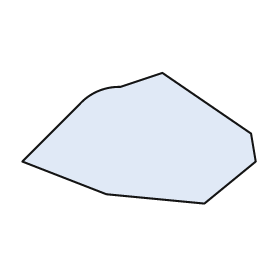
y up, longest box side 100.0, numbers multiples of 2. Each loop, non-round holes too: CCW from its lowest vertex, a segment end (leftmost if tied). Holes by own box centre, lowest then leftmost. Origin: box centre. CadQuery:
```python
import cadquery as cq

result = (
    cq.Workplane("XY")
    .moveTo(28.0, -28.0)
    .lineTo(50.0, -10.0)
    .lineTo(48.0, 2.0)
    .lineTo(10.0, 28.0)
    .lineTo(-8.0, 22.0)
    .threePointArc((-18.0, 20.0), (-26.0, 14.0))
    .lineTo(-50.0, -10.0)
    .lineTo(-14.0, -24.0)
    .close()
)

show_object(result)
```